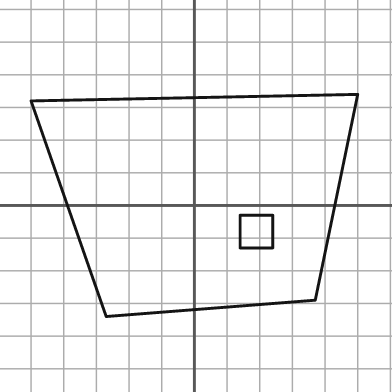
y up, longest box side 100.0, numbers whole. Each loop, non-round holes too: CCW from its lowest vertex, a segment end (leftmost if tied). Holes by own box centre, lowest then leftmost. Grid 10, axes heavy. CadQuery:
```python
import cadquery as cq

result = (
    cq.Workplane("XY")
    .moveTo(-27.0, -34.0)
    .lineTo(37.0, -29.0)
    .lineTo(50.0, 34.0)
    .lineTo(-50.0, 32.0)
    .close()
    .moveTo(14.0, -13.0)
    .lineTo(24.0, -13.0)
    .lineTo(24.0, -3.0)
    .lineTo(14.0, -3.0)
    .close()
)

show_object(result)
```